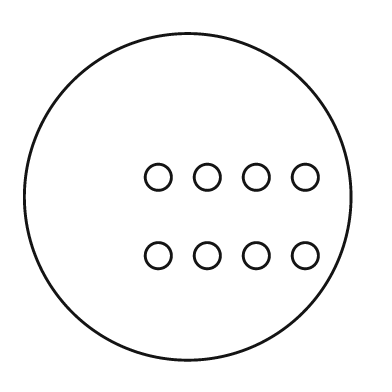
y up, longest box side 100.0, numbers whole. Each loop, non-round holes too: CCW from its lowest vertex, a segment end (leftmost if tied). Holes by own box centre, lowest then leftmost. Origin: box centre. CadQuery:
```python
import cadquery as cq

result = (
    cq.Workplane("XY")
    .moveTo(0.0, 0.0)
    .circle(50.0)
    .moveTo(-9.0, -18.0)
    .circle(4.0)
    .moveTo(6.0, -18.0)
    .circle(4.0)
    .moveTo(21.0, -18.0)
    .circle(4.0)
    .moveTo(36.0, -18.0)
    .circle(4.0)
    .moveTo(-9.0, 6.0)
    .circle(4.0)
    .moveTo(6.0, 6.0)
    .circle(4.0)
    .moveTo(21.0, 6.0)
    .circle(4.0)
    .moveTo(36.0, 6.0)
    .circle(4.0)
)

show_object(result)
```